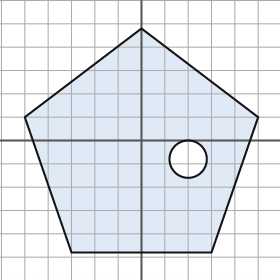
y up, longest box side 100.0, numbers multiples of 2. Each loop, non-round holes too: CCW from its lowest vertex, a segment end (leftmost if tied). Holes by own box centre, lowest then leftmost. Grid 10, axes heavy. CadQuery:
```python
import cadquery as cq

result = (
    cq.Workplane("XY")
    .moveTo(-30.0, -48.0)
    .lineTo(30.0, -48.0)
    .lineTo(50.0, 10.0)
    .lineTo(0.0, 48.0)
    .lineTo(-50.0, 10.0)
    .close()
    .moveTo(20.0, -8.0)
    .circle(8.0)
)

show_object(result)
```